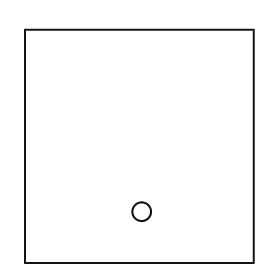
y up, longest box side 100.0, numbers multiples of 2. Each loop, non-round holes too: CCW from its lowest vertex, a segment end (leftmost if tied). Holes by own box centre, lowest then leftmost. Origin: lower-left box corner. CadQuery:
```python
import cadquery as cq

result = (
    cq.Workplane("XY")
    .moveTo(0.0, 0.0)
    .lineTo(98.0, 0.0)
    .lineTo(98.0, 100.0)
    .lineTo(0.0, 100.0)
    .close()
    .moveTo(50.0, 22.0)
    .circle(4.0)
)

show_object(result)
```